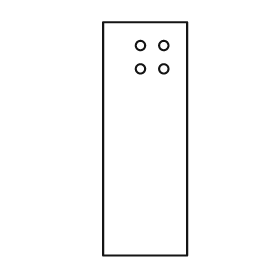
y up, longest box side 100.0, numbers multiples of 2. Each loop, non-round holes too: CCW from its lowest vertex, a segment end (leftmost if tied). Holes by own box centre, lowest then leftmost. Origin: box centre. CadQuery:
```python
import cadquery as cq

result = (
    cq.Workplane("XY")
    .moveTo(-18.0, -50.0)
    .lineTo(18.0, -50.0)
    .lineTo(18.0, 50.0)
    .lineTo(-18.0, 50.0)
    .close()
    .moveTo(-2.0, 30.0)
    .circle(2.0)
    .moveTo(8.0, 30.0)
    .circle(2.0)
    .moveTo(-2.0, 40.0)
    .circle(2.0)
    .moveTo(8.0, 40.0)
    .circle(2.0)
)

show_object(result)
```